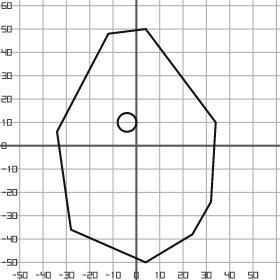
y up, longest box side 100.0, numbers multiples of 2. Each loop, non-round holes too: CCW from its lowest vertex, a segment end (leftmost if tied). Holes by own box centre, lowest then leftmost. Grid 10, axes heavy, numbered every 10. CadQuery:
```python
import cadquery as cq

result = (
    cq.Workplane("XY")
    .moveTo(4.0, -50.0)
    .lineTo(24.0, -38.0)
    .lineTo(32.0, -24.0)
    .lineTo(34.0, 10.0)
    .lineTo(4.0, 50.0)
    .lineTo(-12.0, 48.0)
    .lineTo(-34.0, 6.0)
    .lineTo(-28.0, -36.0)
    .close()
    .moveTo(-4.0, 10.0)
    .circle(4.0)
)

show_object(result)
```